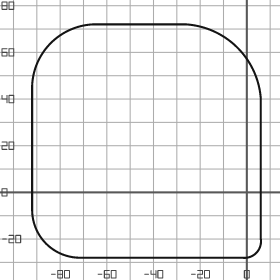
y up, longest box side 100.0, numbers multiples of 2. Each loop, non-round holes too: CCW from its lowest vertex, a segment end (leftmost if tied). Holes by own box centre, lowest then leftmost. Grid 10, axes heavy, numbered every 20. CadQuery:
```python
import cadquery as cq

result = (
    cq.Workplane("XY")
    .moveTo(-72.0, -28.0)
    .lineTo(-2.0, -28.0)
    .threePointArc((4.0, -26.0), (6.0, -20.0))
    .lineTo(6.0, 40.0)
    .threePointArc((-4.0, 62.0), (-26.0, 72.0))
    .lineTo(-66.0, 72.0)
    .threePointArc((-84.0, 64.0), (-92.0, 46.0))
    .lineTo(-92.0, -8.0)
    .threePointArc((-86.0, -22.0), (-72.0, -28.0))
    .close()
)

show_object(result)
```